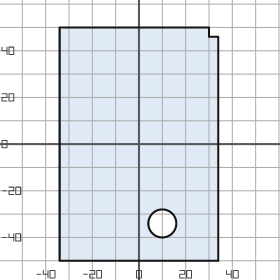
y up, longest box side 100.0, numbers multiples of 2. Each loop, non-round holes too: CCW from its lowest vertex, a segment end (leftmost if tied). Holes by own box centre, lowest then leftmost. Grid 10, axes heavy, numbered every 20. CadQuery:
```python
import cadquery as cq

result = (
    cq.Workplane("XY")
    .moveTo(-34.0, -50.0)
    .lineTo(34.0, -50.0)
    .lineTo(34.0, 46.0)
    .lineTo(30.0, 46.0)
    .lineTo(30.0, 50.0)
    .lineTo(-34.0, 50.0)
    .close()
    .moveTo(10.0, -34.0)
    .circle(6.0)
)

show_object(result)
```